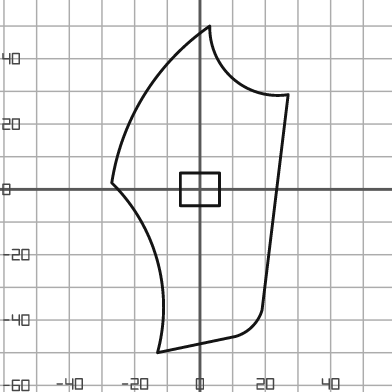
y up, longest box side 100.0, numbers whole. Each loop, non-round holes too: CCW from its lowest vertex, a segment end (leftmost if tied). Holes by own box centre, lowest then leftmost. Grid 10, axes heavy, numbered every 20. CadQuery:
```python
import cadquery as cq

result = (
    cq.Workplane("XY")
    .moveTo(-13.0, -50.0)
    .lineTo(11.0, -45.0)
    .threePointArc((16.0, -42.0), (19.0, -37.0))
    .lineTo(27.0, 29.0)
    .threePointArc((10.0, 34.0), (3.0, 50.0))
    .threePointArc((-17.0, 29.0), (-27.0, 2.0))
    .threePointArc((-13.0, -22.0), (-13.0, -50.0))
    .close()
    .moveTo(-6.0, -5.0)
    .lineTo(6.0, -5.0)
    .lineTo(6.0, 5.0)
    .lineTo(-6.0, 5.0)
    .close()
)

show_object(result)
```